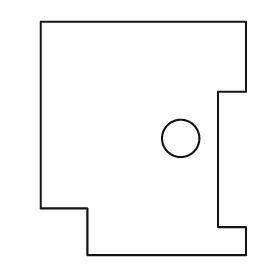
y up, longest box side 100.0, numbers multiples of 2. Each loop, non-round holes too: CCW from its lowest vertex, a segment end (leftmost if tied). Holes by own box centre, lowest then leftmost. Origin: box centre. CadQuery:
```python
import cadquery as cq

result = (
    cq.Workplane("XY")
    .moveTo(-24.0, -50.0)
    .lineTo(44.0, -50.0)
    .lineTo(44.0, -38.0)
    .lineTo(32.0, -38.0)
    .lineTo(32.0, 20.0)
    .lineTo(44.0, 20.0)
    .lineTo(44.0, 50.0)
    .lineTo(-44.0, 50.0)
    .lineTo(-44.0, -30.0)
    .lineTo(-24.0, -30.0)
    .close()
    .moveTo(16.0, 0.0)
    .circle(8.0)
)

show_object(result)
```